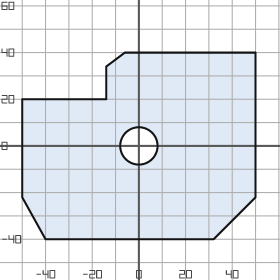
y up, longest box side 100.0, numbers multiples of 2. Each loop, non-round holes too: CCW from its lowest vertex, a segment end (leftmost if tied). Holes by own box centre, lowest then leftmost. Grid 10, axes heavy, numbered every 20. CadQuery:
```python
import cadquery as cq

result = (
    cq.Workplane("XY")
    .moveTo(-40.0, -40.0)
    .lineTo(32.0, -40.0)
    .lineTo(50.0, -22.0)
    .lineTo(50.0, 40.0)
    .lineTo(-6.0, 40.0)
    .lineTo(-14.0, 34.0)
    .lineTo(-14.0, 20.0)
    .lineTo(-50.0, 20.0)
    .lineTo(-50.0, -22.0)
    .close()
    .moveTo(0.0, 0.0)
    .circle(8.0)
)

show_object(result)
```